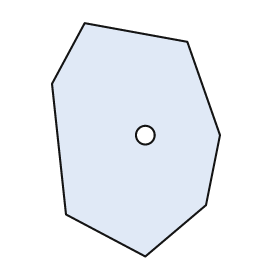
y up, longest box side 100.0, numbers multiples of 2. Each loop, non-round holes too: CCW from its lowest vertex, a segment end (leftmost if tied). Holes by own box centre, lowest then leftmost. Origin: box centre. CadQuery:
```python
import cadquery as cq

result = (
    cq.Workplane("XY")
    .moveTo(4.0, -50.0)
    .lineTo(30.0, -28.0)
    .lineTo(36.0, 2.0)
    .lineTo(22.0, 42.0)
    .lineTo(-22.0, 50.0)
    .lineTo(-36.0, 24.0)
    .lineTo(-30.0, -32.0)
    .close()
    .moveTo(4.0, 2.0)
    .circle(4.0)
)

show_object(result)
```